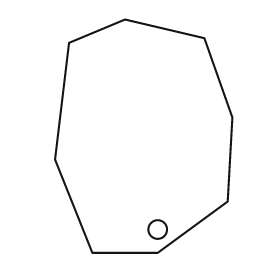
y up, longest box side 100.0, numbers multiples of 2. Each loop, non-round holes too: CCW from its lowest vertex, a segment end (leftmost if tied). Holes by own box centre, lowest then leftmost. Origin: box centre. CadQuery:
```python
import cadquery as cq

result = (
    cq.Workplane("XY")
    .moveTo(-22.0, -50.0)
    .lineTo(6.0, -50.0)
    .lineTo(36.0, -28.0)
    .lineTo(38.0, 8.0)
    .lineTo(26.0, 42.0)
    .lineTo(-8.0, 50.0)
    .lineTo(-32.0, 40.0)
    .lineTo(-38.0, -10.0)
    .close()
    .moveTo(6.0, -40.0)
    .circle(4.0)
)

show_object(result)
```